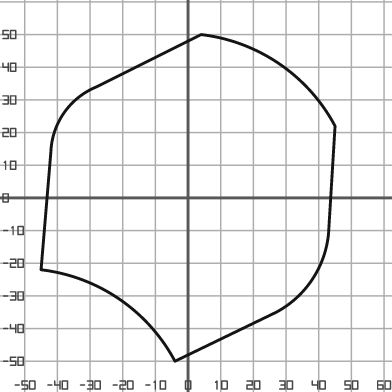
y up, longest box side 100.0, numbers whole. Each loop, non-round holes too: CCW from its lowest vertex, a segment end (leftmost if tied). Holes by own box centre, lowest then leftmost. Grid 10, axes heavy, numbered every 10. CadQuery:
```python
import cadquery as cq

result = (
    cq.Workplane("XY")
    .moveTo(-4.0, -50.0)
    .lineTo(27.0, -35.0)
    .threePointArc((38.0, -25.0), (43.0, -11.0))
    .lineTo(45.0, 22.0)
    .threePointArc((28.0, 41.0), (4.0, 50.0))
    .lineTo(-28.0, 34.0)
    .threePointArc((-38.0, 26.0), (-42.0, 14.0))
    .lineTo(-45.0, -22.0)
    .threePointArc((-21.0, -31.0), (-4.0, -50.0))
    .close()
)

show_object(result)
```